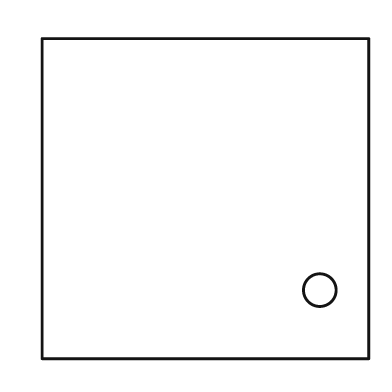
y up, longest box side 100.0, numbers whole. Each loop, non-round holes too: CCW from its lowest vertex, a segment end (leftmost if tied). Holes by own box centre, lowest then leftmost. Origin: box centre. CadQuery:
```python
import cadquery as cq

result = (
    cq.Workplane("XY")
    .moveTo(-50.0, -49.0)
    .lineTo(50.0, -49.0)
    .lineTo(50.0, 49.0)
    .lineTo(-50.0, 49.0)
    .close()
    .moveTo(35.0, -28.0)
    .circle(5.0)
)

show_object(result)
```